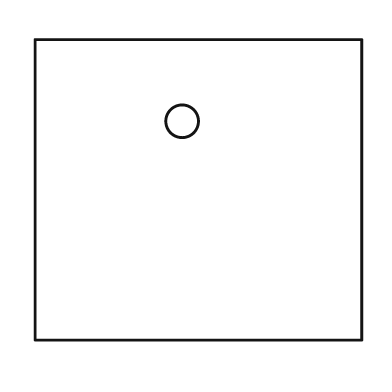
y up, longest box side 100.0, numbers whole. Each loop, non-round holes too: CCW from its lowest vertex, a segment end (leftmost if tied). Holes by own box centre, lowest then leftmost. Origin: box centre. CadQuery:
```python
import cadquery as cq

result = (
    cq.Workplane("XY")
    .moveTo(-50.0, -46.0)
    .lineTo(50.0, -46.0)
    .lineTo(50.0, 46.0)
    .lineTo(-50.0, 46.0)
    .close()
    .moveTo(-5.0, 21.0)
    .circle(5.0)
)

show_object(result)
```